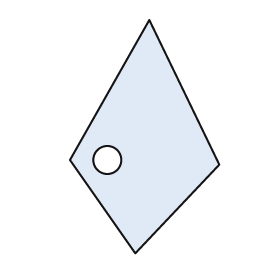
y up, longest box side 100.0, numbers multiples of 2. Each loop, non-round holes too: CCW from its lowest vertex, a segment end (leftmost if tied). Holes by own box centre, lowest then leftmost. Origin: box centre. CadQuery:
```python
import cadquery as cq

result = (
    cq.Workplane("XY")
    .moveTo(-4.0, -50.0)
    .lineTo(32.0, -12.0)
    .lineTo(2.0, 50.0)
    .lineTo(-32.0, -10.0)
    .close()
    .moveTo(-16.0, -10.0)
    .circle(6.0)
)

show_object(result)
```